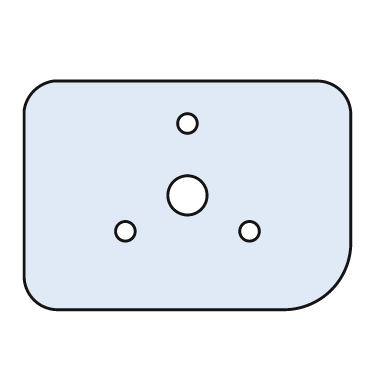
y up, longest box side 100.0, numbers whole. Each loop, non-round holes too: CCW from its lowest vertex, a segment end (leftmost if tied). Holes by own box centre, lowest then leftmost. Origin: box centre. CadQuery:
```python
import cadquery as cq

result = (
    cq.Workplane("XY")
    .moveTo(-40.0, -35.0)
    .lineTo(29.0, -35.0)
    .threePointArc((44.0, -29.0), (50.0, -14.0))
    .lineTo(50.0, 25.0)
    .threePointArc((47.0, 32.0), (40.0, 35.0))
    .lineTo(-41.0, 35.0)
    .threePointArc((-47.0, 32.0), (-50.0, 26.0))
    .lineTo(-50.0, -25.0)
    .threePointArc((-47.0, -32.0), (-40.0, -35.0))
    .close()
    .moveTo(-19.0, -11.0)
    .circle(3.0)
    .moveTo(19.0, -11.0)
    .circle(3.0)
    .moveTo(0.0, 0.0)
    .circle(6.0)
    .moveTo(0.0, 22.0)
    .circle(3.0)
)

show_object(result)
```